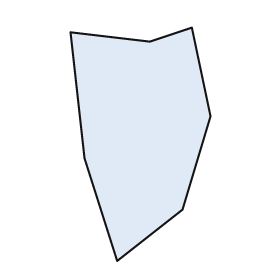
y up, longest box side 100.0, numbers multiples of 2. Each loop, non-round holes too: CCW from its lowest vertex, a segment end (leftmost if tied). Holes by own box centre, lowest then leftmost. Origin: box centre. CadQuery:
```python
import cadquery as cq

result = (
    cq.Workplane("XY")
    .moveTo(-10.0, -50.0)
    .lineTo(18.0, -28.0)
    .lineTo(30.0, 12.0)
    .lineTo(22.0, 50.0)
    .lineTo(4.0, 44.0)
    .lineTo(-30.0, 48.0)
    .lineTo(-24.0, -6.0)
    .close()
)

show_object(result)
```